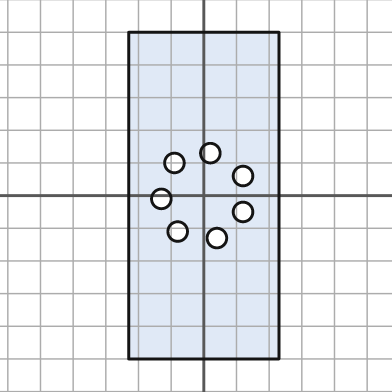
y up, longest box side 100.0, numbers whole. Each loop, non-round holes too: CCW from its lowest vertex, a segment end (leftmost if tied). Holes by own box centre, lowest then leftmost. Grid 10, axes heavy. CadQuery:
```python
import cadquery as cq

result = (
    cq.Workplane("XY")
    .moveTo(-23.0, -50.0)
    .lineTo(23.0, -50.0)
    .lineTo(23.0, 50.0)
    .lineTo(-23.0, 50.0)
    .close()
    .moveTo(4.0, -13.0)
    .circle(3.0)
    .moveTo(-8.0, -11.0)
    .circle(3.0)
    .moveTo(12.0, -5.0)
    .circle(3.0)
    .moveTo(-13.0, -1.0)
    .circle(3.0)
    .moveTo(12.0, 6.0)
    .circle(3.0)
    .moveTo(-9.0, 10.0)
    .circle(3.0)
    .moveTo(2.0, 13.0)
    .circle(3.0)
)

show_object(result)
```